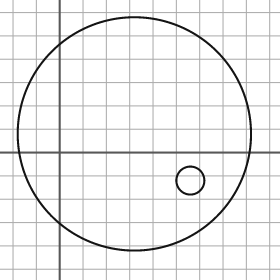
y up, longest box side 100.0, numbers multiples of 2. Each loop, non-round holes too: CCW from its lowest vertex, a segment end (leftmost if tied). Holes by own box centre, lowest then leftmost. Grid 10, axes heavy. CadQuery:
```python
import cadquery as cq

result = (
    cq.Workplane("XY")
    .moveTo(32.0, 8.0)
    .circle(50.0)
    .moveTo(56.0, -12.0)
    .circle(6.0)
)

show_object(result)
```